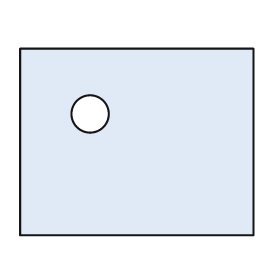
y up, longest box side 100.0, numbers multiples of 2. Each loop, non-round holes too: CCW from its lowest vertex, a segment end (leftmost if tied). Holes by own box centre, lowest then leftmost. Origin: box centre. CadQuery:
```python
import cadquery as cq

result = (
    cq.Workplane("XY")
    .moveTo(-50.0, -40.0)
    .lineTo(50.0, -40.0)
    .lineTo(50.0, 40.0)
    .lineTo(-50.0, 40.0)
    .close()
    .moveTo(-20.0, 12.0)
    .circle(8.0)
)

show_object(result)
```